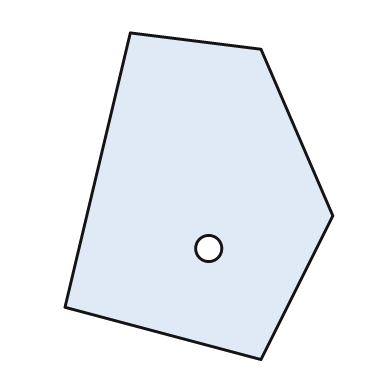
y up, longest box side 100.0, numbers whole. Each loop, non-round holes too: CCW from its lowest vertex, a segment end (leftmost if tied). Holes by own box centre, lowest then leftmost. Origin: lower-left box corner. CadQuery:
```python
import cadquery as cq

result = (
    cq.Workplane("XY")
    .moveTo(60.0, 0.0)
    .lineTo(82.0, 44.0)
    .lineTo(60.0, 95.0)
    .lineTo(20.0, 100.0)
    .lineTo(0.0, 16.0)
    .close()
    .moveTo(44.0, 34.0)
    .circle(4.0)
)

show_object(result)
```